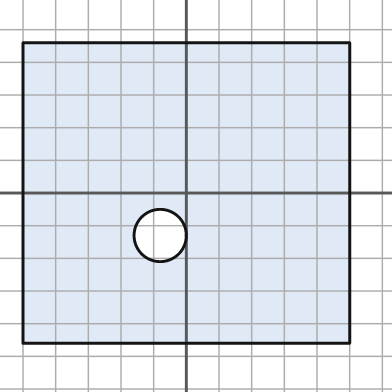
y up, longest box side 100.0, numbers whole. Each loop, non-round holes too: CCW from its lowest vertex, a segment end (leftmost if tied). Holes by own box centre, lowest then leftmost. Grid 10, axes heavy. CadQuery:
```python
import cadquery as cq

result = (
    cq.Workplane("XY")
    .moveTo(-50.0, -46.0)
    .lineTo(50.0, -46.0)
    .lineTo(50.0, 46.0)
    .lineTo(-50.0, 46.0)
    .close()
    .moveTo(-8.0, -13.0)
    .circle(8.0)
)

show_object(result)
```